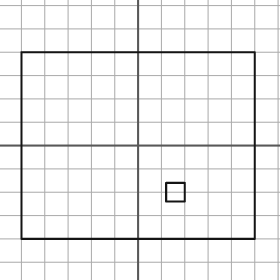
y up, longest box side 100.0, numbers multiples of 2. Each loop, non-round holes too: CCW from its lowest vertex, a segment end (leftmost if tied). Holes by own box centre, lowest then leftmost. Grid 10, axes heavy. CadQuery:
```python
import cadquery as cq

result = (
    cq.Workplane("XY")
    .moveTo(-50.0, -40.0)
    .lineTo(50.0, -40.0)
    .lineTo(50.0, 40.0)
    .lineTo(-50.0, 40.0)
    .close()
    .moveTo(12.0, -24.0)
    .lineTo(20.0, -24.0)
    .lineTo(20.0, -16.0)
    .lineTo(12.0, -16.0)
    .close()
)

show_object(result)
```